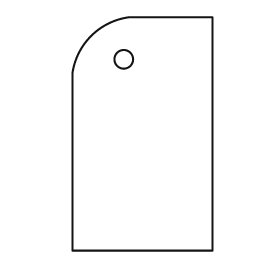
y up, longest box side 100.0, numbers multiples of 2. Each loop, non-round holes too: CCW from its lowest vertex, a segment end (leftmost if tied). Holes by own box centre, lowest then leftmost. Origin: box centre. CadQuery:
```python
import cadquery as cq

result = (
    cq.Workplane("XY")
    .moveTo(-30.0, -50.0)
    .lineTo(30.0, -50.0)
    .lineTo(30.0, 50.0)
    .lineTo(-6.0, 50.0)
    .threePointArc((-22.0, 42.0), (-30.0, 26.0))
    .close()
    .moveTo(-8.0, 32.0)
    .circle(4.0)
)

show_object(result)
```